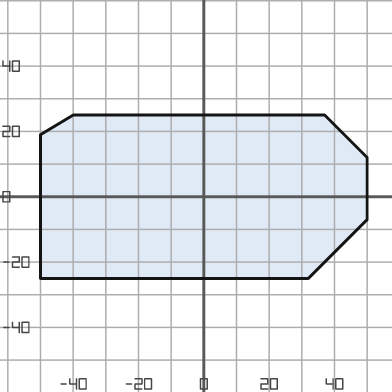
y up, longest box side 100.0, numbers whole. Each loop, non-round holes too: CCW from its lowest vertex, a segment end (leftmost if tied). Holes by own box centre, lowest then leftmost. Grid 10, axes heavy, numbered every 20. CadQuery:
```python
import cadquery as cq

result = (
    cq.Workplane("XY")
    .moveTo(-50.0, -25.0)
    .lineTo(32.0, -25.0)
    .lineTo(50.0, -7.0)
    .lineTo(50.0, 12.0)
    .lineTo(37.0, 25.0)
    .lineTo(-40.0, 25.0)
    .lineTo(-50.0, 19.0)
    .close()
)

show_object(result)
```